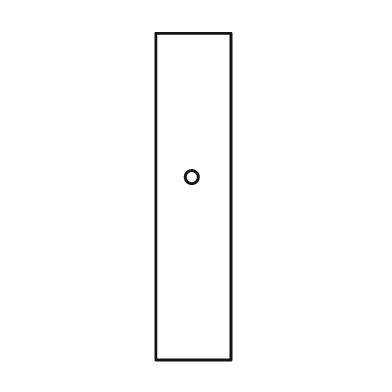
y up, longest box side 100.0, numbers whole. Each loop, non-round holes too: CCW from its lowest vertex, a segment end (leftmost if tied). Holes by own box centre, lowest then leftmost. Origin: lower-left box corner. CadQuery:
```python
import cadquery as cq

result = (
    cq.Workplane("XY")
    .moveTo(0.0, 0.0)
    .lineTo(23.0, 0.0)
    .lineTo(23.0, 100.0)
    .lineTo(0.0, 100.0)
    .close()
    .moveTo(11.0, 56.0)
    .circle(2.0)
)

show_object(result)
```